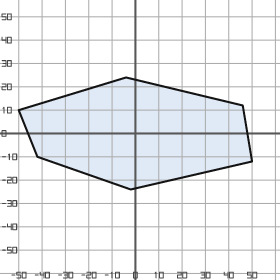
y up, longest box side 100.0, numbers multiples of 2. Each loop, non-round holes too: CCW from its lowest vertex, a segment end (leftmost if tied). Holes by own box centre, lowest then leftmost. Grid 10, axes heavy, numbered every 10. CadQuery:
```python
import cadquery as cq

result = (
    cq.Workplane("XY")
    .moveTo(-2.0, -24.0)
    .lineTo(50.0, -12.0)
    .lineTo(46.0, 12.0)
    .lineTo(-4.0, 24.0)
    .lineTo(-50.0, 10.0)
    .lineTo(-42.0, -10.0)
    .close()
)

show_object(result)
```